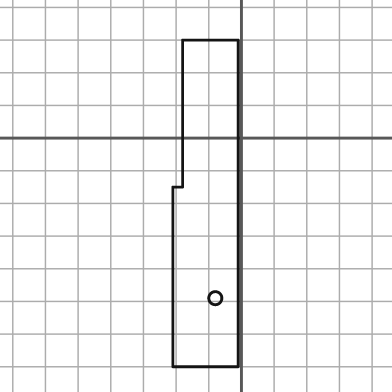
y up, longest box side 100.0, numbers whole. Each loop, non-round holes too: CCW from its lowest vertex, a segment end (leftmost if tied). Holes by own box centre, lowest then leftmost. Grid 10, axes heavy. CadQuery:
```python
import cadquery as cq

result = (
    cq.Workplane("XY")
    .moveTo(-21.0, -70.0)
    .lineTo(-1.0, -70.0)
    .lineTo(-1.0, 30.0)
    .lineTo(-18.0, 30.0)
    .lineTo(-18.0, -15.0)
    .lineTo(-21.0, -15.0)
    .close()
    .moveTo(-8.0, -49.0)
    .circle(2.0)
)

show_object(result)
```